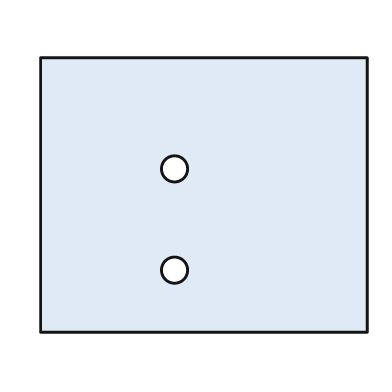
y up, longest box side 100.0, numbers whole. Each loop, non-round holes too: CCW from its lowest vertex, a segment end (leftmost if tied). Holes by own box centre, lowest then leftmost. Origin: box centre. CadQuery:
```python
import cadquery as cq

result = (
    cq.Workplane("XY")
    .moveTo(-50.0, -42.0)
    .lineTo(50.0, -42.0)
    .lineTo(50.0, 42.0)
    .lineTo(-50.0, 42.0)
    .close()
    .moveTo(-9.0, -23.0)
    .circle(4.0)
    .moveTo(-9.0, 8.0)
    .circle(4.0)
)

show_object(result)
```